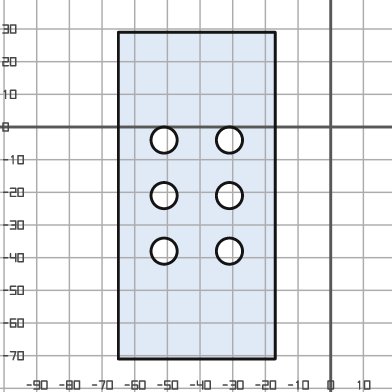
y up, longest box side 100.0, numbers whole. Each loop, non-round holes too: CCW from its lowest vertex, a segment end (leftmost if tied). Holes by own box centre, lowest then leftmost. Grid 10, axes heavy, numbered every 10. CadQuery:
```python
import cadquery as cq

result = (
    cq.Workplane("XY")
    .moveTo(-65.0, -71.0)
    .lineTo(-17.0, -71.0)
    .lineTo(-17.0, 29.0)
    .lineTo(-65.0, 29.0)
    .close()
    .moveTo(-51.0, -38.0)
    .circle(4.0)
    .moveTo(-31.0, -38.0)
    .circle(4.0)
    .moveTo(-51.0, -21.0)
    .circle(4.0)
    .moveTo(-31.0, -21.0)
    .circle(4.0)
    .moveTo(-51.0, -4.0)
    .circle(4.0)
    .moveTo(-31.0, -4.0)
    .circle(4.0)
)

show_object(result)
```